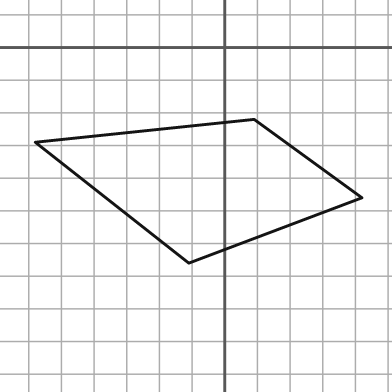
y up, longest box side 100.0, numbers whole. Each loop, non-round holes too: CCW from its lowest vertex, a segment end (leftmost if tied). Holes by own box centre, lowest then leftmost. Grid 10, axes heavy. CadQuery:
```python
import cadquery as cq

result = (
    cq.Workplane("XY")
    .moveTo(-11.0, -66.0)
    .lineTo(42.0, -46.0)
    .lineTo(9.0, -22.0)
    .lineTo(-58.0, -29.0)
    .close()
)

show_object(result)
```